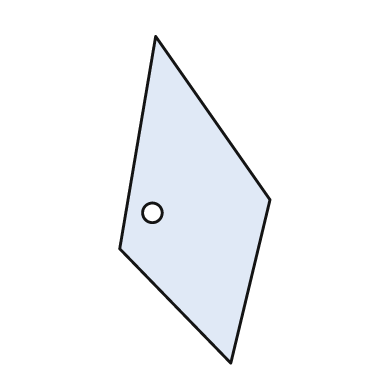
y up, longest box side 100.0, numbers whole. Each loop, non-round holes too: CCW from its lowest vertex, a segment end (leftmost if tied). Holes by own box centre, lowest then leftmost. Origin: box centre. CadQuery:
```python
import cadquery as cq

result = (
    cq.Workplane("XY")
    .moveTo(11.0, -50.0)
    .lineTo(23.0, 0.0)
    .lineTo(-12.0, 50.0)
    .lineTo(-23.0, -15.0)
    .close()
    .moveTo(-13.0, -4.0)
    .circle(3.0)
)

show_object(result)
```